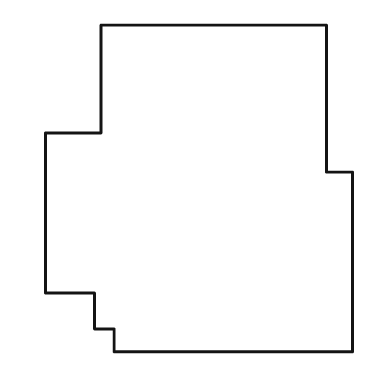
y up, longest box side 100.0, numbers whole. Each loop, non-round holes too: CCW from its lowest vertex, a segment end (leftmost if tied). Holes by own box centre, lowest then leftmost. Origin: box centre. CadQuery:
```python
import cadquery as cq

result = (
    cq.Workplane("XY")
    .moveTo(-26.0, -50.0)
    .lineTo(47.0, -50.0)
    .lineTo(47.0, 5.0)
    .lineTo(39.0, 5.0)
    .lineTo(39.0, 50.0)
    .lineTo(-30.0, 50.0)
    .lineTo(-30.0, 17.0)
    .lineTo(-47.0, 17.0)
    .lineTo(-47.0, -32.0)
    .lineTo(-32.0, -32.0)
    .lineTo(-32.0, -43.0)
    .lineTo(-26.0, -43.0)
    .close()
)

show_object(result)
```